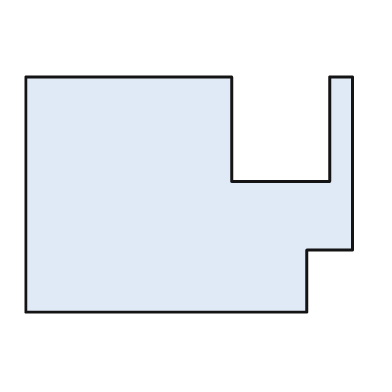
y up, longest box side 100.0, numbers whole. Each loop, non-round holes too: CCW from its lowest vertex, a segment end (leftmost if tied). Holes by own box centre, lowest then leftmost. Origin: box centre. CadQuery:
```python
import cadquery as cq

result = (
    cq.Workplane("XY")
    .moveTo(-50.0, -36.0)
    .lineTo(36.0, -36.0)
    .lineTo(36.0, -17.0)
    .lineTo(50.0, -17.0)
    .lineTo(50.0, 36.0)
    .lineTo(43.0, 36.0)
    .lineTo(43.0, 4.0)
    .lineTo(13.0, 4.0)
    .lineTo(13.0, 36.0)
    .lineTo(-50.0, 36.0)
    .close()
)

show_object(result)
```